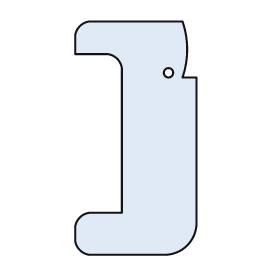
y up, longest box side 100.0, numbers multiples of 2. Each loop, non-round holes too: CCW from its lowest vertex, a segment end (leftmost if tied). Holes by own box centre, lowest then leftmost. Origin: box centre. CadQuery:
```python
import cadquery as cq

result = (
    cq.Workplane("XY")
    .moveTo(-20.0, -50.0)
    .lineTo(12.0, -50.0)
    .threePointArc((22.0, -46.0), (26.0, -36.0))
    .lineTo(26.0, 26.0)
    .lineTo(20.0, 26.0)
    .threePointArc((22.0, 38.0), (20.0, 50.0))
    .lineTo(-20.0, 50.0)
    .threePointArc((-24.0, 48.0), (-26.0, 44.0))
    .lineTo(-26.0, 36.0)
    .lineTo(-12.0, 36.0)
    .threePointArc((-8.0, 34.0), (-6.0, 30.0))
    .lineTo(-6.0, -32.0)
    .lineTo(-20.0, -32.0)
    .threePointArc((-24.0, -34.0), (-26.0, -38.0))
    .lineTo(-26.0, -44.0)
    .threePointArc((-24.0, -48.0), (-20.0, -50.0))
    .close()
    .moveTo(14.0, 28.0)
    .circle(2.0)
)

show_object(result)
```